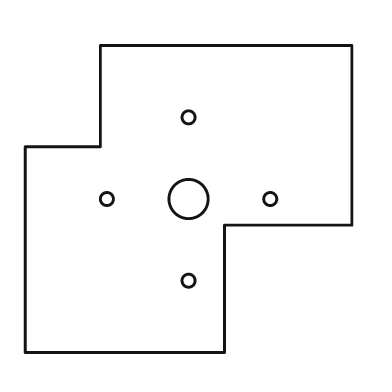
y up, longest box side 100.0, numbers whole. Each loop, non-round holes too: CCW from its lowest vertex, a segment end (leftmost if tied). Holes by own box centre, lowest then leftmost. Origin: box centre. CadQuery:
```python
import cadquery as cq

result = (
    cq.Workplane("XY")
    .moveTo(-50.0, -47.0)
    .lineTo(11.0, -47.0)
    .lineTo(11.0, -8.0)
    .lineTo(50.0, -8.0)
    .lineTo(50.0, 47.0)
    .lineTo(-27.0, 47.0)
    .lineTo(-27.0, 16.0)
    .lineTo(-50.0, 16.0)
    .close()
    .moveTo(0.0, -25.0)
    .circle(2.0)
    .moveTo(-25.0, 0.0)
    .circle(2.0)
    .moveTo(0.0, 0.0)
    .circle(6.0)
    .moveTo(25.0, 0.0)
    .circle(2.0)
    .moveTo(0.0, 25.0)
    .circle(2.0)
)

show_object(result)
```